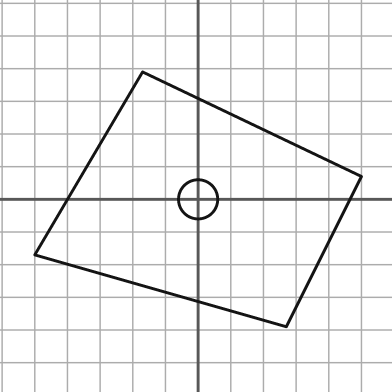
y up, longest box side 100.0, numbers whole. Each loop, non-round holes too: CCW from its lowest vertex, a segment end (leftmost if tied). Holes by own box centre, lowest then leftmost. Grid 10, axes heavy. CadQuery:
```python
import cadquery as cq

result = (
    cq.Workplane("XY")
    .moveTo(27.0, -39.0)
    .lineTo(50.0, 7.0)
    .lineTo(-17.0, 39.0)
    .lineTo(-50.0, -17.0)
    .close()
    .moveTo(0.0, 0.0)
    .circle(6.0)
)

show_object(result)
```